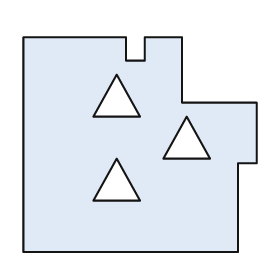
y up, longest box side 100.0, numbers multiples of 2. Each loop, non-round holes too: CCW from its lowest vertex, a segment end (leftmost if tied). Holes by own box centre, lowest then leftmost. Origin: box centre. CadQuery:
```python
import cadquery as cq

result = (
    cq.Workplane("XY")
    .moveTo(-50.0, -46.0)
    .lineTo(42.0, -46.0)
    .lineTo(42.0, -8.0)
    .lineTo(50.0, -8.0)
    .lineTo(50.0, 18.0)
    .lineTo(18.0, 18.0)
    .lineTo(18.0, 46.0)
    .lineTo(2.0, 46.0)
    .lineTo(2.0, 36.0)
    .lineTo(-6.0, 36.0)
    .lineTo(-6.0, 46.0)
    .lineTo(-50.0, 46.0)
    .close()
    .moveTo(-20.0, -24.0)
    .lineTo(0.0, -24.0)
    .lineTo(-10.0, -6.0)
    .close()
    .moveTo(10.0, -6.0)
    .lineTo(30.0, -6.0)
    .lineTo(20.0, 12.0)
    .close()
    .moveTo(-20.0, 12.0)
    .lineTo(0.0, 12.0)
    .lineTo(-10.0, 30.0)
    .close()
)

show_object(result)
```